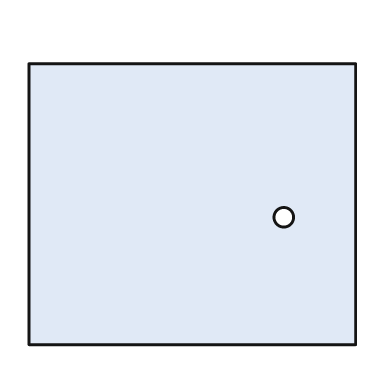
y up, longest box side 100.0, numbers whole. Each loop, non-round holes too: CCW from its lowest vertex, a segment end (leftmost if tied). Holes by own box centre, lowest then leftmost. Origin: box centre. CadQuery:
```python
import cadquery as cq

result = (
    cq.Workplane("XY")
    .moveTo(-50.0, -43.0)
    .lineTo(50.0, -43.0)
    .lineTo(50.0, 43.0)
    .lineTo(-50.0, 43.0)
    .close()
    .moveTo(28.0, -4.0)
    .circle(3.0)
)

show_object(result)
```